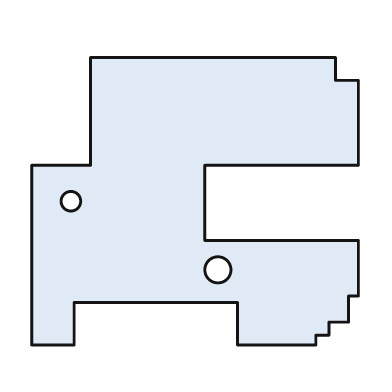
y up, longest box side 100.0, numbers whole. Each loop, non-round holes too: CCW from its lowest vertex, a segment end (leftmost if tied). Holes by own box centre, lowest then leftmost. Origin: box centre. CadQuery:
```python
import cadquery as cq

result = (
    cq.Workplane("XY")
    .moveTo(-50.0, -44.0)
    .lineTo(-37.0, -44.0)
    .lineTo(-37.0, -31.0)
    .lineTo(13.0, -31.0)
    .lineTo(13.0, -44.0)
    .lineTo(37.0, -44.0)
    .lineTo(37.0, -41.0)
    .lineTo(41.0, -41.0)
    .lineTo(41.0, -37.0)
    .lineTo(47.0, -37.0)
    .lineTo(47.0, -29.0)
    .lineTo(50.0, -29.0)
    .lineTo(50.0, -12.0)
    .lineTo(3.0, -12.0)
    .lineTo(3.0, 11.0)
    .lineTo(50.0, 11.0)
    .lineTo(50.0, 37.0)
    .lineTo(43.0, 37.0)
    .lineTo(43.0, 44.0)
    .lineTo(-32.0, 44.0)
    .lineTo(-32.0, 11.0)
    .lineTo(-50.0, 11.0)
    .close()
    .moveTo(7.0, -21.0)
    .circle(4.0)
    .moveTo(-38.0, 0.0)
    .circle(3.0)
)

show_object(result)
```